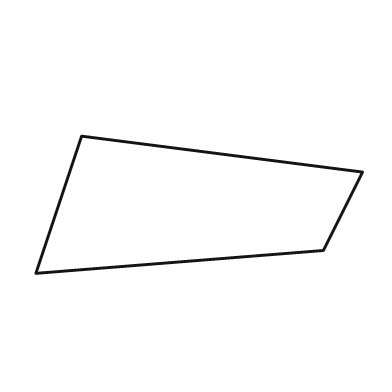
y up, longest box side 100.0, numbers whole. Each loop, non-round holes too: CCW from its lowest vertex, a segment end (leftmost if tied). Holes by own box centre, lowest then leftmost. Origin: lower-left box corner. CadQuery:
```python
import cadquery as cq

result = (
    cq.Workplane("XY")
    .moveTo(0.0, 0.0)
    .lineTo(88.0, 7.0)
    .lineTo(100.0, 31.0)
    .lineTo(14.0, 42.0)
    .close()
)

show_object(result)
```